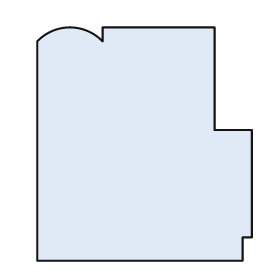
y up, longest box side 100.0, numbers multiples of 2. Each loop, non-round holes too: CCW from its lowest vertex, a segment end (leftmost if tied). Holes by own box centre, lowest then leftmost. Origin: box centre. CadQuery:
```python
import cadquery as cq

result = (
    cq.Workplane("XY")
    .moveTo(-46.0, -50.0)
    .lineTo(42.0, -50.0)
    .lineTo(42.0, -40.0)
    .lineTo(46.0, -40.0)
    .lineTo(46.0, 6.0)
    .lineTo(30.0, 6.0)
    .lineTo(30.0, 50.0)
    .lineTo(-18.0, 50.0)
    .lineTo(-18.0, 44.0)
    .threePointArc((-32.0, 50.0), (-46.0, 44.0))
    .close()
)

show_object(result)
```